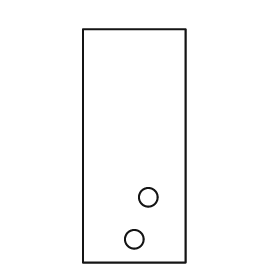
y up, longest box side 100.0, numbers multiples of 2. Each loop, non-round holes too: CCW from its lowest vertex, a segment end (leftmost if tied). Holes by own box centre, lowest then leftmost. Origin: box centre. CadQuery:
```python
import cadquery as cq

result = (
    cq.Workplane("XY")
    .moveTo(-22.0, -50.0)
    .lineTo(22.0, -50.0)
    .lineTo(22.0, 50.0)
    .lineTo(-22.0, 50.0)
    .close()
    .moveTo(0.0, -40.0)
    .circle(4.0)
    .moveTo(6.0, -22.0)
    .circle(4.0)
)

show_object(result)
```